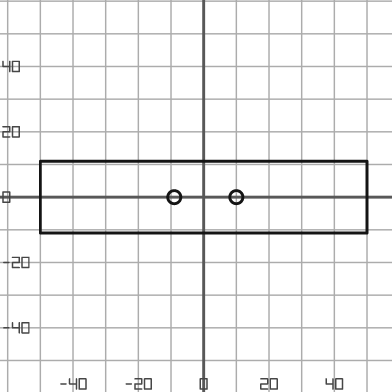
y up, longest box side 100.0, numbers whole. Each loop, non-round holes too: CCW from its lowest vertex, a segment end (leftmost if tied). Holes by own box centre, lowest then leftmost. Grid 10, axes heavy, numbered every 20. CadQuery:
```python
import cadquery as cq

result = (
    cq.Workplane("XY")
    .moveTo(-50.0, -11.0)
    .lineTo(50.0, -11.0)
    .lineTo(50.0, 11.0)
    .lineTo(-50.0, 11.0)
    .close()
    .moveTo(-9.0, 0.0)
    .circle(2.0)
    .moveTo(10.0, 0.0)
    .circle(2.0)
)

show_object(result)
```